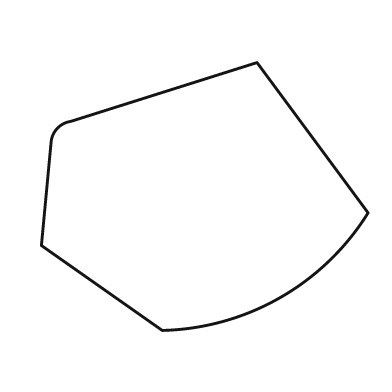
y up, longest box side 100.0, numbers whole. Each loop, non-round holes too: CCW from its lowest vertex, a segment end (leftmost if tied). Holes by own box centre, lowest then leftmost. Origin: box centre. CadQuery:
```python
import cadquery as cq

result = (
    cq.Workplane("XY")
    .moveTo(-13.0, -41.0)
    .threePointArc((23.0, -31.0), (50.0, -5.0))
    .lineTo(16.0, 41.0)
    .lineTo(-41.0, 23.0)
    .threePointArc((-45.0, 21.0), (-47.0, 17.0))
    .lineTo(-50.0, -15.0)
    .close()
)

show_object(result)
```